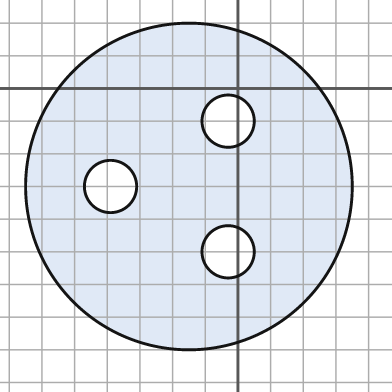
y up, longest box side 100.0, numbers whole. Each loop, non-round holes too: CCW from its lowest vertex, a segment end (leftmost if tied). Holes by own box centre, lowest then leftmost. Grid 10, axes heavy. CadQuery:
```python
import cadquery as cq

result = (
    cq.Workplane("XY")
    .moveTo(-15.0, -30.0)
    .circle(50.0)
    .moveTo(-3.0, -50.0)
    .circle(8.0)
    .moveTo(-39.0, -30.0)
    .circle(8.0)
    .moveTo(-3.0, -10.0)
    .circle(8.0)
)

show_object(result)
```